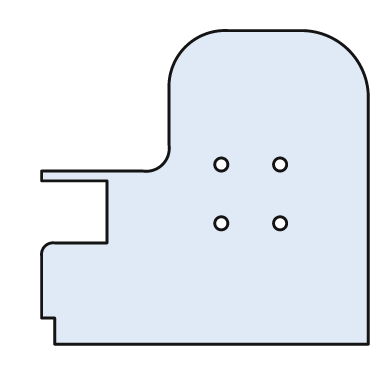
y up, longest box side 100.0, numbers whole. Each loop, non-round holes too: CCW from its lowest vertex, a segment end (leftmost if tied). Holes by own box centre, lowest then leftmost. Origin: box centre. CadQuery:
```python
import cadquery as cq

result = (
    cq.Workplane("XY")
    .moveTo(-46.0, -48.0)
    .lineTo(50.0, -48.0)
    .lineTo(50.0, 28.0)
    .threePointArc((44.0, 42.0), (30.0, 48.0))
    .lineTo(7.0, 48.0)
    .threePointArc((-6.0, 43.0), (-11.0, 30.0))
    .lineTo(-11.0, 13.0)
    .threePointArc((-13.0, 7.0), (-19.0, 5.0))
    .lineTo(-50.0, 5.0)
    .lineTo(-50.0, 2.0)
    .lineTo(-30.0, 2.0)
    .lineTo(-30.0, -17.0)
    .lineTo(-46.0, -17.0)
    .threePointArc((-49.0, -18.0), (-50.0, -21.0))
    .lineTo(-50.0, -40.0)
    .lineTo(-46.0, -40.0)
    .close()
    .moveTo(5.0, -11.0)
    .circle(2.0)
    .moveTo(23.0, -11.0)
    .circle(2.0)
    .moveTo(5.0, 7.0)
    .circle(2.0)
    .moveTo(23.0, 7.0)
    .circle(2.0)
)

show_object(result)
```